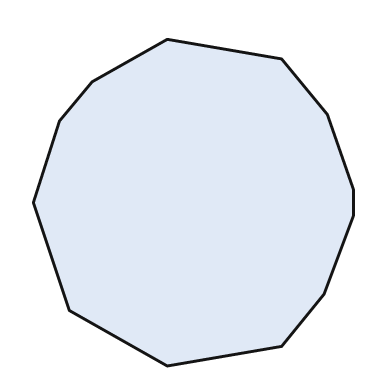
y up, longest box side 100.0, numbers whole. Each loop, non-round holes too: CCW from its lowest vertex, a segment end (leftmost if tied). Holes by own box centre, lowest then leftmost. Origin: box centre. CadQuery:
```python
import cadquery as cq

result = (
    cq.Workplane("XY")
    .moveTo(-8.0, -50.0)
    .lineTo(27.0, -44.0)
    .lineTo(40.0, -28.0)
    .lineTo(49.0, -4.0)
    .lineTo(49.0, 4.0)
    .lineTo(41.0, 27.0)
    .lineTo(27.0, 44.0)
    .lineTo(-8.0, 50.0)
    .lineTo(-31.0, 37.0)
    .lineTo(-41.0, 25.0)
    .lineTo(-49.0, 0.0)
    .lineTo(-38.0, -33.0)
    .close()
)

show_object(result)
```